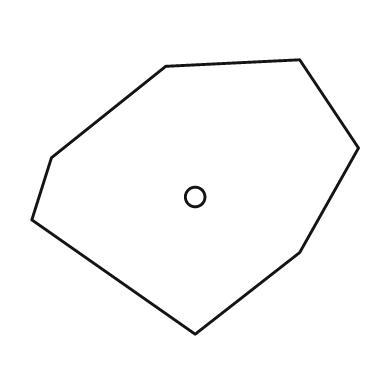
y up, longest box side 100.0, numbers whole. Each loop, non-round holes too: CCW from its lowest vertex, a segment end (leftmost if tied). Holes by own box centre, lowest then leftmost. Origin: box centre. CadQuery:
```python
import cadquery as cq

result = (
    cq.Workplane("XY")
    .moveTo(0.0, -42.0)
    .lineTo(32.0, -17.0)
    .lineTo(50.0, 15.0)
    .lineTo(32.0, 42.0)
    .lineTo(-9.0, 40.0)
    .lineTo(-44.0, 12.0)
    .lineTo(-50.0, -7.0)
    .close()
    .moveTo(0.0, 0.0)
    .circle(3.0)
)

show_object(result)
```